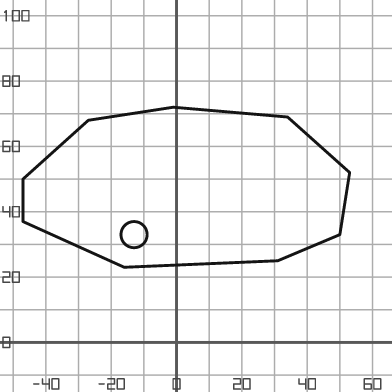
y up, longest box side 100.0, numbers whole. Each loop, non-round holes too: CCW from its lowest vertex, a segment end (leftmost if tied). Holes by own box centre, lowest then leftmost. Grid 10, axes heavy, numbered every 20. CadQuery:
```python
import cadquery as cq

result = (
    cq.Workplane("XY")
    .moveTo(-16.0, 23.0)
    .lineTo(31.0, 25.0)
    .lineTo(50.0, 33.0)
    .lineTo(53.0, 52.0)
    .lineTo(34.0, 69.0)
    .lineTo(-1.0, 72.0)
    .lineTo(-27.0, 68.0)
    .lineTo(-47.0, 50.0)
    .lineTo(-47.0, 37.0)
    .close()
    .moveTo(-13.0, 33.0)
    .circle(4.0)
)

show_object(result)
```